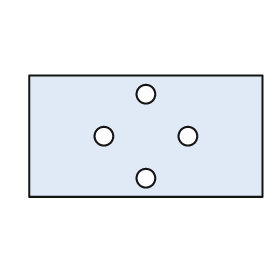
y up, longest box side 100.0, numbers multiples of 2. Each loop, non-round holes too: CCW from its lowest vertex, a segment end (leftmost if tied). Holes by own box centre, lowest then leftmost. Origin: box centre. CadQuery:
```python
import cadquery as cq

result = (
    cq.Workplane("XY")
    .moveTo(-50.0, -26.0)
    .lineTo(50.0, -26.0)
    .lineTo(50.0, 26.0)
    .lineTo(-50.0, 26.0)
    .close()
    .moveTo(0.0, -18.0)
    .circle(4.0)
    .moveTo(-18.0, 0.0)
    .circle(4.0)
    .moveTo(18.0, 0.0)
    .circle(4.0)
    .moveTo(0.0, 18.0)
    .circle(4.0)
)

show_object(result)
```